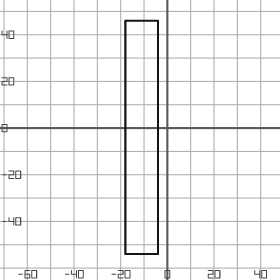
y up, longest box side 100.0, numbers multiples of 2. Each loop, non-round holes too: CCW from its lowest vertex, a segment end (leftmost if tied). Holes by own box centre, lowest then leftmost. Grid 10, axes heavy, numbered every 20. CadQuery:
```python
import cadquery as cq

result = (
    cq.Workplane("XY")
    .moveTo(-18.0, -54.0)
    .lineTo(-4.0, -54.0)
    .lineTo(-4.0, 46.0)
    .lineTo(-18.0, 46.0)
    .close()
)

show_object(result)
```